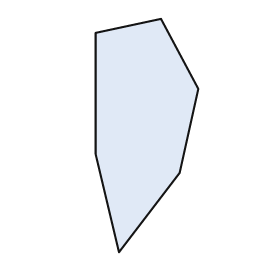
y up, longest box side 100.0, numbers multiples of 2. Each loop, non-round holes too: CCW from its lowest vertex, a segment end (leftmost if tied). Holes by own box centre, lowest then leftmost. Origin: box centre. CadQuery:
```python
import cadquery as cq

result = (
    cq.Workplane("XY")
    .moveTo(-12.0, -50.0)
    .lineTo(14.0, -16.0)
    .lineTo(22.0, 20.0)
    .lineTo(6.0, 50.0)
    .lineTo(-22.0, 44.0)
    .lineTo(-22.0, -8.0)
    .close()
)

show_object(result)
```